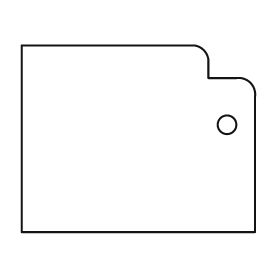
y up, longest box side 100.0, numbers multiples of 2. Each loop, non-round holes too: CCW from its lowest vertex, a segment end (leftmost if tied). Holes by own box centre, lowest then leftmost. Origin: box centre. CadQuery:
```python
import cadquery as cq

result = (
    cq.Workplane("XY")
    .moveTo(-50.0, -40.0)
    .lineTo(50.0, -40.0)
    .lineTo(50.0, 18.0)
    .threePointArc((48.0, 24.0), (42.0, 26.0))
    .lineTo(30.0, 26.0)
    .lineTo(30.0, 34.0)
    .threePointArc((28.0, 38.0), (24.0, 40.0))
    .lineTo(-50.0, 40.0)
    .close()
    .moveTo(38.0, 6.0)
    .circle(4.0)
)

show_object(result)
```